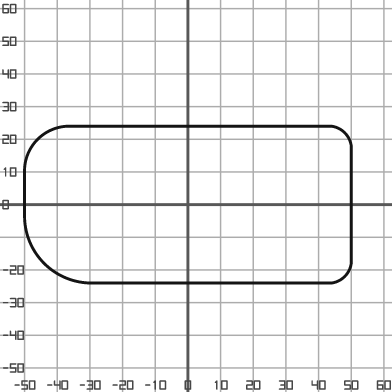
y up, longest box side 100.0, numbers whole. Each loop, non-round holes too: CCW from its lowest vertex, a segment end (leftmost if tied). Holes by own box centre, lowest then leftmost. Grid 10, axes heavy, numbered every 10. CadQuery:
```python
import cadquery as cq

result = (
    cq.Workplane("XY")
    .moveTo(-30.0, -24.0)
    .lineTo(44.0, -24.0)
    .threePointArc((48.0, -22.0), (50.0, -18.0))
    .lineTo(50.0, 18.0)
    .threePointArc((48.0, 22.0), (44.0, 24.0))
    .lineTo(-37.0, 24.0)
    .threePointArc((-46.0, 20.0), (-50.0, 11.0))
    .lineTo(-50.0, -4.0)
    .threePointArc((-44.0, -18.0), (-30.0, -24.0))
    .close()
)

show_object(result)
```